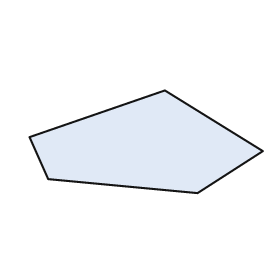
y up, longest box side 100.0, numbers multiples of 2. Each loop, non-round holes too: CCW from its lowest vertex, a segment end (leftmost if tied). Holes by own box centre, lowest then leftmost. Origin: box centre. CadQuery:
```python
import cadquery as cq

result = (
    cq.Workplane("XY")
    .moveTo(22.0, -22.0)
    .lineTo(50.0, -4.0)
    .lineTo(8.0, 22.0)
    .lineTo(-50.0, 2.0)
    .lineTo(-42.0, -16.0)
    .close()
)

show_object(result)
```